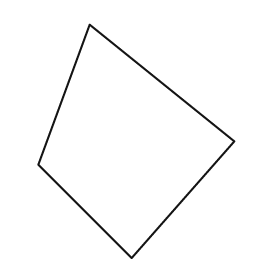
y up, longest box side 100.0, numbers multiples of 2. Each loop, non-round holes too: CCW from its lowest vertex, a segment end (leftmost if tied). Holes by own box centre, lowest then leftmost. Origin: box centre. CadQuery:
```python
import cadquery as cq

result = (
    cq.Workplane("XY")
    .moveTo(-2.0, -50.0)
    .lineTo(42.0, 0.0)
    .lineTo(-20.0, 50.0)
    .lineTo(-42.0, -10.0)
    .close()
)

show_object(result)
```